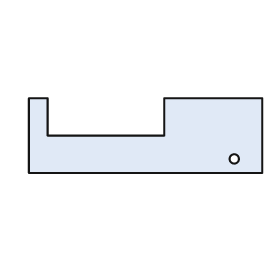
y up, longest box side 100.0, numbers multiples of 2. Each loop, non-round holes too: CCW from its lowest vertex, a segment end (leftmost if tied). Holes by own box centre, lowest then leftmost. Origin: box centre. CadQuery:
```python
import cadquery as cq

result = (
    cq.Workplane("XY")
    .moveTo(-50.0, -16.0)
    .lineTo(50.0, -16.0)
    .lineTo(50.0, 16.0)
    .lineTo(8.0, 16.0)
    .lineTo(8.0, 0.0)
    .lineTo(-42.0, 0.0)
    .lineTo(-42.0, 16.0)
    .lineTo(-50.0, 16.0)
    .close()
    .moveTo(38.0, -10.0)
    .circle(2.0)
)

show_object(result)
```